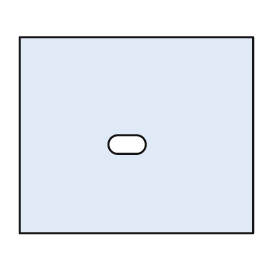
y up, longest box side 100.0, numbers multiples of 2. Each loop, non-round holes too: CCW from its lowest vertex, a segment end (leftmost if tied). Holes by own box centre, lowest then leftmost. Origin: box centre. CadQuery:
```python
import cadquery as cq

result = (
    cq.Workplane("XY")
    .moveTo(-50.0, -42.0)
    .lineTo(50.0, -42.0)
    .lineTo(50.0, 42.0)
    .lineTo(-50.0, 42.0)
    .close()
    .moveTo(-8.0, -8.0)
    .lineTo(0.0, -8.0)
    .threePointArc((4.0, -4.0), (0.0, 0.0))
    .lineTo(-8.0, 0.0)
    .threePointArc((-12.0, -4.0), (-8.0, -8.0))
    .close()
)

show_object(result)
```